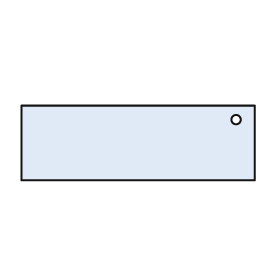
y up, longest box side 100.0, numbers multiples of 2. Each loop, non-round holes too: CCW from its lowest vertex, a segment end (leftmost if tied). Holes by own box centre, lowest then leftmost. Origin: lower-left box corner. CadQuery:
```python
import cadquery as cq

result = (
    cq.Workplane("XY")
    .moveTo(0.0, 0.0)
    .lineTo(100.0, 0.0)
    .lineTo(100.0, 32.0)
    .lineTo(0.0, 32.0)
    .close()
    .moveTo(92.0, 26.0)
    .circle(2.0)
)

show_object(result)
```